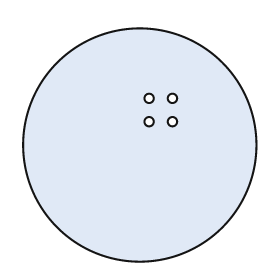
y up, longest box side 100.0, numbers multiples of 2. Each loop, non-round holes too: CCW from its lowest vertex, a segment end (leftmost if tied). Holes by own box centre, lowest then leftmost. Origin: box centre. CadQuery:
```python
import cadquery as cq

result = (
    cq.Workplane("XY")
    .moveTo(0.0, 0.0)
    .circle(50.0)
    .moveTo(4.0, 10.0)
    .circle(2.0)
    .moveTo(14.0, 10.0)
    .circle(2.0)
    .moveTo(4.0, 20.0)
    .circle(2.0)
    .moveTo(14.0, 20.0)
    .circle(2.0)
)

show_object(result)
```